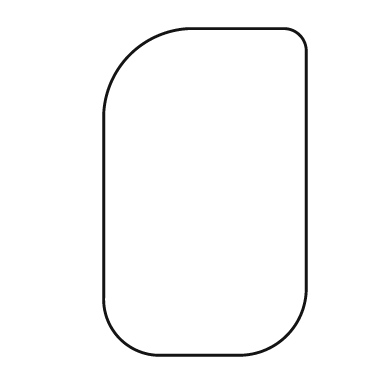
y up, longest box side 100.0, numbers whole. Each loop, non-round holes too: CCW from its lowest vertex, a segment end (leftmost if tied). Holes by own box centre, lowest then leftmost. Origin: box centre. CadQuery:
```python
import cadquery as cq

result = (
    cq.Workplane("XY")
    .moveTo(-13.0, -50.0)
    .lineTo(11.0, -50.0)
    .threePointArc((25.0, -44.0), (31.0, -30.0))
    .lineTo(31.0, 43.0)
    .threePointArc((29.0, 48.0), (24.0, 50.0))
    .lineTo(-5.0, 50.0)
    .threePointArc((-23.0, 42.0), (-31.0, 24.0))
    .lineTo(-31.0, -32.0)
    .threePointArc((-26.0, -45.0), (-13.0, -50.0))
    .close()
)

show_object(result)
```